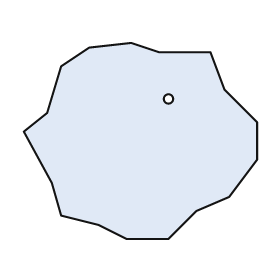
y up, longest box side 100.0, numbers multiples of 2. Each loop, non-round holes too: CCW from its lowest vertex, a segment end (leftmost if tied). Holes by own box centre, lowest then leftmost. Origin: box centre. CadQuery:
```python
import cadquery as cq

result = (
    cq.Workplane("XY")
    .moveTo(-6.0, -42.0)
    .lineTo(12.0, -42.0)
    .lineTo(24.0, -30.0)
    .lineTo(38.0, -24.0)
    .lineTo(50.0, -8.0)
    .lineTo(50.0, 8.0)
    .lineTo(36.0, 22.0)
    .lineTo(30.0, 38.0)
    .lineTo(8.0, 38.0)
    .lineTo(-4.0, 42.0)
    .lineTo(-22.0, 40.0)
    .lineTo(-34.0, 32.0)
    .lineTo(-40.0, 12.0)
    .lineTo(-50.0, 4.0)
    .lineTo(-38.0, -18.0)
    .lineTo(-34.0, -32.0)
    .lineTo(-18.0, -36.0)
    .close()
    .moveTo(12.0, 18.0)
    .circle(2.0)
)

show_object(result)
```